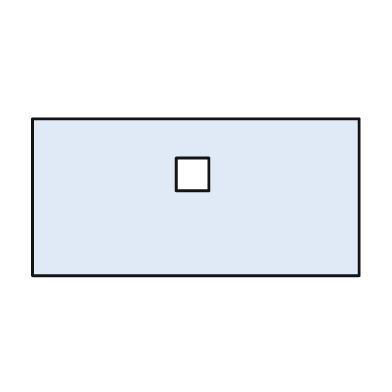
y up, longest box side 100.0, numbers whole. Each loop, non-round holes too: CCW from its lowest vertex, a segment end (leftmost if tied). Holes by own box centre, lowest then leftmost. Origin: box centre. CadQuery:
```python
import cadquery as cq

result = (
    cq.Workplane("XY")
    .moveTo(-50.0, -24.0)
    .lineTo(50.0, -24.0)
    .lineTo(50.0, 24.0)
    .lineTo(-50.0, 24.0)
    .close()
    .moveTo(-6.0, 2.0)
    .lineTo(4.0, 2.0)
    .lineTo(4.0, 12.0)
    .lineTo(-6.0, 12.0)
    .close()
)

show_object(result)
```